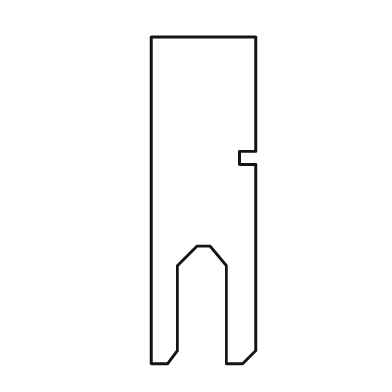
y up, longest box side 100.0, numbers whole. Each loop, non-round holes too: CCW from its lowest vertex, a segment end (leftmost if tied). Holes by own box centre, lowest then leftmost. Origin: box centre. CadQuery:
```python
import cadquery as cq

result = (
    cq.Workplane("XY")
    .moveTo(-16.0, -50.0)
    .lineTo(-11.0, -50.0)
    .lineTo(-8.0, -46.0)
    .lineTo(-8.0, -20.0)
    .lineTo(-2.0, -14.0)
    .lineTo(2.0, -14.0)
    .lineTo(7.0, -20.0)
    .lineTo(7.0, -50.0)
    .lineTo(12.0, -50.0)
    .lineTo(16.0, -46.0)
    .lineTo(16.0, 11.0)
    .lineTo(11.0, 11.0)
    .lineTo(11.0, 15.0)
    .lineTo(16.0, 15.0)
    .lineTo(16.0, 50.0)
    .lineTo(-16.0, 50.0)
    .close()
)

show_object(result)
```